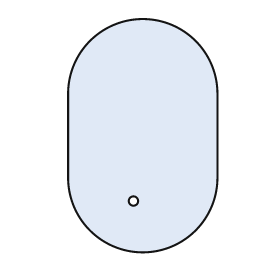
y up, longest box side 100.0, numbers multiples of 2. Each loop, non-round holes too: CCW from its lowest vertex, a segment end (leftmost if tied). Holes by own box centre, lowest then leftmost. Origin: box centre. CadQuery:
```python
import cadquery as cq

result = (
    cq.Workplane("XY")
    .moveTo(-32.0, -18.0)
    .threePointArc((0.0, -50.0), (32.0, -18.0))
    .lineTo(32.0, 18.0)
    .threePointArc((0.0, 50.0), (-32.0, 18.0))
    .close()
    .moveTo(-4.0, -28.0)
    .circle(2.0)
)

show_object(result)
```